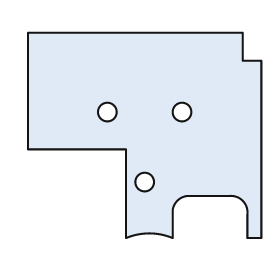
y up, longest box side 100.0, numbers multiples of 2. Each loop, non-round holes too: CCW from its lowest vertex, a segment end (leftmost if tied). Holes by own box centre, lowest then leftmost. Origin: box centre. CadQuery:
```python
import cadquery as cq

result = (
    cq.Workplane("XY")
    .moveTo(-8.0, -44.0)
    .threePointArc((2.0, -42.0), (12.0, -44.0))
    .lineTo(12.0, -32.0)
    .threePointArc((14.0, -28.0), (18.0, -26.0))
    .lineTo(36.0, -26.0)
    .threePointArc((42.0, -28.0), (44.0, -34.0))
    .lineTo(44.0, -44.0)
    .lineTo(50.0, -44.0)
    .lineTo(50.0, 32.0)
    .lineTo(42.0, 32.0)
    .lineTo(42.0, 44.0)
    .lineTo(-50.0, 44.0)
    .lineTo(-50.0, -6.0)
    .lineTo(-8.0, -6.0)
    .close()
    .moveTo(0.0, -20.0)
    .circle(4.0)
    .moveTo(-16.0, 10.0)
    .circle(4.0)
    .moveTo(16.0, 10.0)
    .circle(4.0)
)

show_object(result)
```